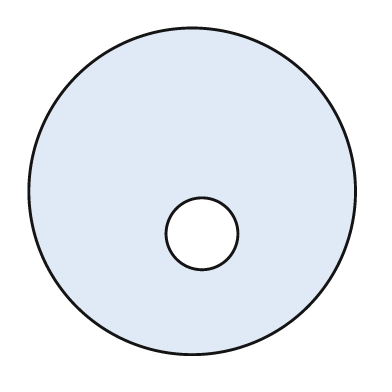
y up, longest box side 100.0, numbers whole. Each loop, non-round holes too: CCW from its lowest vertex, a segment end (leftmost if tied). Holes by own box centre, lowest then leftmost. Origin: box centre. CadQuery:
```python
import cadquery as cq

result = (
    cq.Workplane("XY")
    .moveTo(0.0, 0.0)
    .circle(50.0)
    .moveTo(3.0, -13.0)
    .circle(11.0)
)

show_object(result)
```